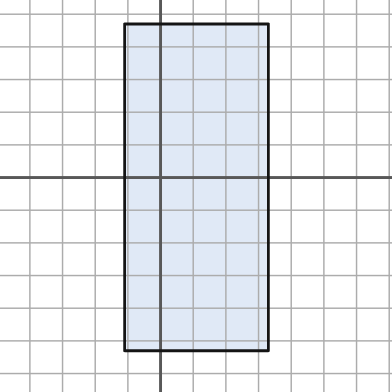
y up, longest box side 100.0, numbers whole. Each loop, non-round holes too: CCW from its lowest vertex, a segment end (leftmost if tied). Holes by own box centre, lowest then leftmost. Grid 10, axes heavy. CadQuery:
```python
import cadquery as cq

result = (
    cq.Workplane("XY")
    .moveTo(-11.0, -53.0)
    .lineTo(33.0, -53.0)
    .lineTo(33.0, 47.0)
    .lineTo(-11.0, 47.0)
    .close()
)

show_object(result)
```